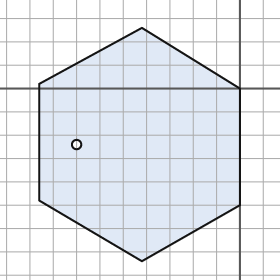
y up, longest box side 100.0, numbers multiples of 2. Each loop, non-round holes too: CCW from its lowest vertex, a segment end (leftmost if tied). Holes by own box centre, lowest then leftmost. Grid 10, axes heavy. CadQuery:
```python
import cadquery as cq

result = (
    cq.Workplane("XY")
    .moveTo(-42.0, -74.0)
    .lineTo(0.0, -50.0)
    .lineTo(0.0, 0.0)
    .lineTo(-42.0, 26.0)
    .lineTo(-86.0, 2.0)
    .lineTo(-86.0, -48.0)
    .close()
    .moveTo(-70.0, -24.0)
    .circle(2.0)
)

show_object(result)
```